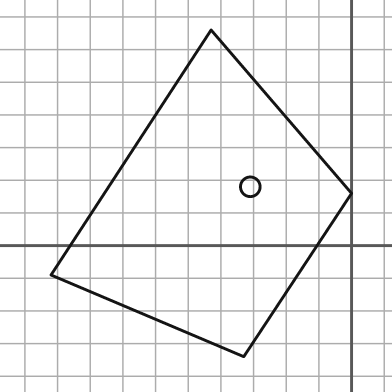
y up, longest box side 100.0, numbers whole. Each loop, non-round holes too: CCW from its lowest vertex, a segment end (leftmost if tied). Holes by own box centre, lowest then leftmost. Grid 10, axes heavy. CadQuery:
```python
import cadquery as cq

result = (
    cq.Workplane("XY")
    .moveTo(-33.0, -34.0)
    .lineTo(0.0, 16.0)
    .lineTo(-43.0, 66.0)
    .lineTo(-92.0, -9.0)
    .close()
    .moveTo(-31.0, 18.0)
    .circle(3.0)
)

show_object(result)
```